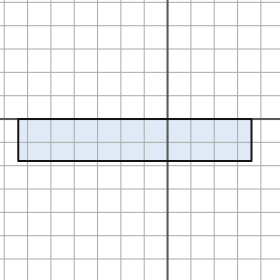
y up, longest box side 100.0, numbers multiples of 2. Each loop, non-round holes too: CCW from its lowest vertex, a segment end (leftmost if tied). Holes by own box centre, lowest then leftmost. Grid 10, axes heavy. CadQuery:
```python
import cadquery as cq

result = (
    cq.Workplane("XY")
    .moveTo(-64.0, -18.0)
    .lineTo(36.0, -18.0)
    .lineTo(36.0, 0.0)
    .lineTo(-64.0, 0.0)
    .close()
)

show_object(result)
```